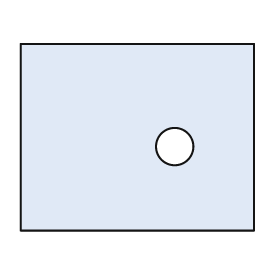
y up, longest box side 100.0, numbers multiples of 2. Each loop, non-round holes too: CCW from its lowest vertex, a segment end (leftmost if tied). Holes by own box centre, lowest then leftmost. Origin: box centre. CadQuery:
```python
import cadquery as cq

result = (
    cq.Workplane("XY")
    .moveTo(-50.0, -40.0)
    .lineTo(50.0, -40.0)
    .lineTo(50.0, 40.0)
    .lineTo(-50.0, 40.0)
    .close()
    .moveTo(16.0, -4.0)
    .circle(8.0)
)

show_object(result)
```